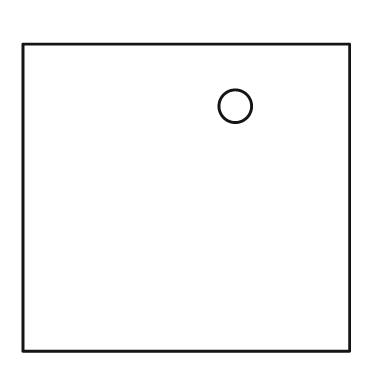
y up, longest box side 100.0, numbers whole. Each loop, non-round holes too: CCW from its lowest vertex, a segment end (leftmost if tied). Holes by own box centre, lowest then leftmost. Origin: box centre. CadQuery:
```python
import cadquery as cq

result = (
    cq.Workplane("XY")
    .moveTo(-50.0, -47.0)
    .lineTo(50.0, -47.0)
    .lineTo(50.0, 47.0)
    .lineTo(-50.0, 47.0)
    .close()
    .moveTo(15.0, 28.0)
    .circle(5.0)
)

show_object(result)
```